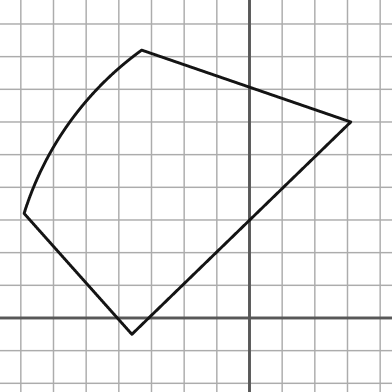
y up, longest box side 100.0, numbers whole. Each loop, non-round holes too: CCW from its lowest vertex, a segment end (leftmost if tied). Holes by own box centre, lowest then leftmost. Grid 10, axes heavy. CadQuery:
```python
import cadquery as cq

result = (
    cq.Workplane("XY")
    .moveTo(-36.0, -5.0)
    .lineTo(31.0, 60.0)
    .lineTo(-33.0, 82.0)
    .threePointArc((-55.0, 60.0), (-69.0, 32.0))
    .close()
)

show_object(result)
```